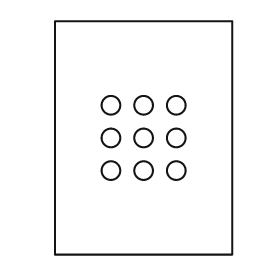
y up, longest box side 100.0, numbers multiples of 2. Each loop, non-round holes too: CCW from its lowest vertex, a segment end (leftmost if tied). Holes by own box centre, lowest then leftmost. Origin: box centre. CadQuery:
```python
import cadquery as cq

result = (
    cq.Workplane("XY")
    .moveTo(-38.0, -50.0)
    .lineTo(38.0, -50.0)
    .lineTo(38.0, 50.0)
    .lineTo(-38.0, 50.0)
    .close()
    .moveTo(-14.0, -14.0)
    .circle(4.0)
    .moveTo(0.0, -14.0)
    .circle(4.0)
    .moveTo(14.0, -14.0)
    .circle(4.0)
    .moveTo(-14.0, 0.0)
    .circle(4.0)
    .moveTo(0.0, 0.0)
    .circle(4.0)
    .moveTo(14.0, 0.0)
    .circle(4.0)
    .moveTo(-14.0, 14.0)
    .circle(4.0)
    .moveTo(0.0, 14.0)
    .circle(4.0)
    .moveTo(14.0, 14.0)
    .circle(4.0)
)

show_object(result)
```